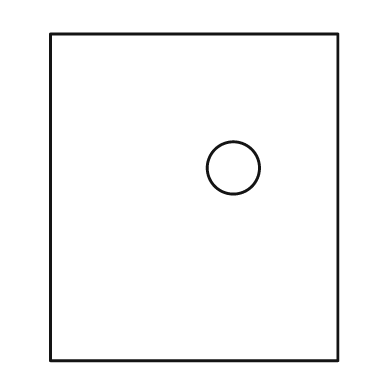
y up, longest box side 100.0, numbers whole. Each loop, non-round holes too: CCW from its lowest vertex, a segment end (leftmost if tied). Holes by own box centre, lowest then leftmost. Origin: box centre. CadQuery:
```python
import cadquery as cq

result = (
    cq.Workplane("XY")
    .moveTo(-44.0, -50.0)
    .lineTo(44.0, -50.0)
    .lineTo(44.0, 50.0)
    .lineTo(-44.0, 50.0)
    .close()
    .moveTo(12.0, 9.0)
    .circle(8.0)
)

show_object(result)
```